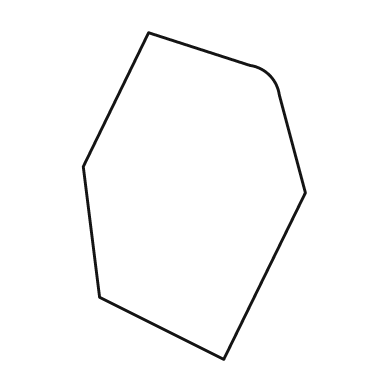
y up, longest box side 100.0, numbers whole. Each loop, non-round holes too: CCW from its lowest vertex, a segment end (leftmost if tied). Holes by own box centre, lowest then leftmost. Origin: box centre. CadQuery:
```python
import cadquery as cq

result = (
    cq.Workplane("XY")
    .moveTo(9.0, -50.0)
    .lineTo(34.0, 1.0)
    .lineTo(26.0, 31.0)
    .threePointArc((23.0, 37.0), (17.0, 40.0))
    .lineTo(-14.0, 50.0)
    .lineTo(-34.0, 9.0)
    .lineTo(-29.0, -31.0)
    .close()
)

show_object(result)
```